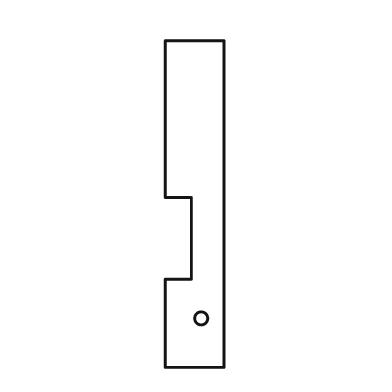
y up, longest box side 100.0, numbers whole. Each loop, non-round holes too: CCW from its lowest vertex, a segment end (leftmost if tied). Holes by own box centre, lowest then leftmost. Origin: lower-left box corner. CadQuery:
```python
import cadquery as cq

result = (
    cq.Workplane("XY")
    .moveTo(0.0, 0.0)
    .lineTo(18.0, 0.0)
    .lineTo(18.0, 100.0)
    .lineTo(0.0, 100.0)
    .lineTo(0.0, 52.0)
    .lineTo(8.0, 52.0)
    .lineTo(8.0, 27.0)
    .lineTo(0.0, 27.0)
    .close()
    .moveTo(11.0, 15.0)
    .circle(2.0)
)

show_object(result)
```